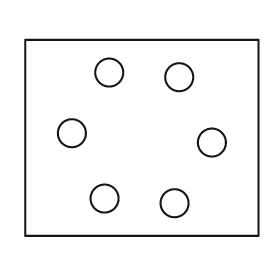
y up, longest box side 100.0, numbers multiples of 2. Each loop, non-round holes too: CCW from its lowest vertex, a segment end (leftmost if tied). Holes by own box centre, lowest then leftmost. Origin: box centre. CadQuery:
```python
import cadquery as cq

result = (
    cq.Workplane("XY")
    .moveTo(-50.0, -42.0)
    .lineTo(50.0, -42.0)
    .lineTo(50.0, 42.0)
    .lineTo(-50.0, 42.0)
    .close()
    .moveTo(14.0, -28.0)
    .circle(6.0)
    .moveTo(-16.0, -26.0)
    .circle(6.0)
    .moveTo(30.0, -2.0)
    .circle(6.0)
    .moveTo(-30.0, 2.0)
    .circle(6.0)
    .moveTo(16.0, 26.0)
    .circle(6.0)
    .moveTo(-14.0, 28.0)
    .circle(6.0)
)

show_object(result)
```